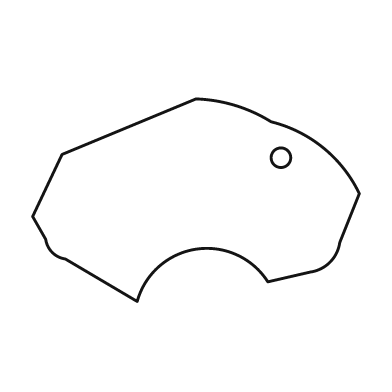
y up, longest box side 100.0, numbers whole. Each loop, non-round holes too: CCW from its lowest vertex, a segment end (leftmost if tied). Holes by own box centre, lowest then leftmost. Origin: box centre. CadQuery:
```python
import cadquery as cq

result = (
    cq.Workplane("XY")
    .moveTo(-18.0, -31.0)
    .threePointArc((0.0, -15.0), (22.0, -25.0))
    .lineTo(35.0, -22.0)
    .threePointArc((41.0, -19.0), (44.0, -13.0))
    .lineTo(50.0, 2.0)
    .threePointArc((39.0, 16.0), (23.0, 24.0))
    .threePointArc((12.0, 29.0), (0.0, 31.0))
    .lineTo(-41.0, 14.0)
    .lineTo(-50.0, -5.0)
    .lineTo(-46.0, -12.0)
    .threePointArc((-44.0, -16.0), (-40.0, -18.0))
    .close()
    .moveTo(26.0, 13.0)
    .circle(3.0)
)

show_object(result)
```